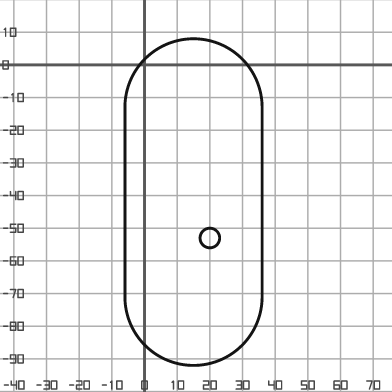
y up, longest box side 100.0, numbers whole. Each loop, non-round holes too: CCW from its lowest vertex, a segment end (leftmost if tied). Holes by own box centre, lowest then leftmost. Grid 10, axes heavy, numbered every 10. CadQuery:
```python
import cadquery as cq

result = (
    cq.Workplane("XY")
    .moveTo(-6.0, -71.0)
    .threePointArc((15.0, -92.0), (36.0, -71.0))
    .lineTo(36.0, -13.0)
    .threePointArc((15.0, 8.0), (-6.0, -13.0))
    .close()
    .moveTo(20.0, -53.0)
    .circle(3.0)
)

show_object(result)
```